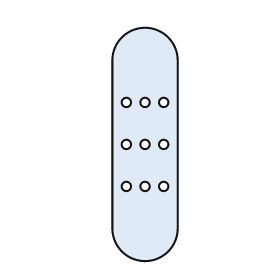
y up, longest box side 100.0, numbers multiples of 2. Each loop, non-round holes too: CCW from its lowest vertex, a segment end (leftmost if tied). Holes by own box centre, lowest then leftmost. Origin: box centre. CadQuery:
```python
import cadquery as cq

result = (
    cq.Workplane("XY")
    .moveTo(-14.0, -36.0)
    .threePointArc((0.0, -50.0), (14.0, -36.0))
    .lineTo(14.0, 36.0)
    .threePointArc((0.0, 50.0), (-14.0, 36.0))
    .close()
    .moveTo(-8.0, -18.0)
    .circle(2.0)
    .moveTo(0.0, -18.0)
    .circle(2.0)
    .moveTo(8.0, -18.0)
    .circle(2.0)
    .moveTo(-8.0, 0.0)
    .circle(2.0)
    .moveTo(0.0, 0.0)
    .circle(2.0)
    .moveTo(8.0, 0.0)
    .circle(2.0)
    .moveTo(-8.0, 18.0)
    .circle(2.0)
    .moveTo(0.0, 18.0)
    .circle(2.0)
    .moveTo(8.0, 18.0)
    .circle(2.0)
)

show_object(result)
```